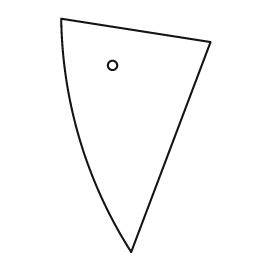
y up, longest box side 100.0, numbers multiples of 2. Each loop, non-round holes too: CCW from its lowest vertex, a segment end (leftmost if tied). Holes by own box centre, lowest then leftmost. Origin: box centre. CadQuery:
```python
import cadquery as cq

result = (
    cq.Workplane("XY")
    .moveTo(-2.0, -50.0)
    .lineTo(32.0, 40.0)
    .lineTo(-32.0, 50.0)
    .threePointArc((-24.0, -2.0), (-2.0, -50.0))
    .close()
    .moveTo(-10.0, 30.0)
    .circle(2.0)
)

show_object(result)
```